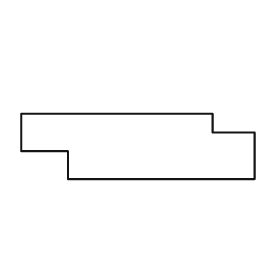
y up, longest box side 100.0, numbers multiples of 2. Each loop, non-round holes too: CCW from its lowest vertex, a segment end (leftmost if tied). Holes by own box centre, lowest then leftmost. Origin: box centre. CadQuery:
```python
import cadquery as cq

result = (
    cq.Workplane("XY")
    .moveTo(-30.0, -14.0)
    .lineTo(50.0, -14.0)
    .lineTo(50.0, 6.0)
    .lineTo(32.0, 6.0)
    .lineTo(32.0, 14.0)
    .lineTo(-50.0, 14.0)
    .lineTo(-50.0, -2.0)
    .lineTo(-30.0, -2.0)
    .close()
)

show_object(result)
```